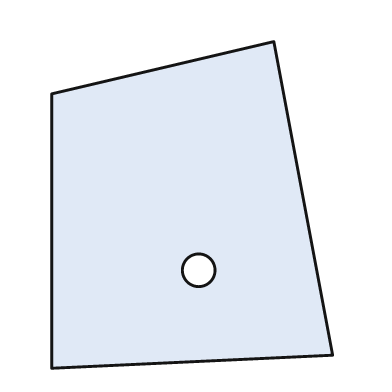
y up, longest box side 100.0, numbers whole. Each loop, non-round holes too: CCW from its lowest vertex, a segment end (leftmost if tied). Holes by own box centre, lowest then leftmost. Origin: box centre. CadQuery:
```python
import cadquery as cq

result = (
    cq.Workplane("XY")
    .moveTo(-43.0, -50.0)
    .lineTo(43.0, -46.0)
    .lineTo(25.0, 50.0)
    .lineTo(-43.0, 34.0)
    .close()
    .moveTo(2.0, -20.0)
    .circle(5.0)
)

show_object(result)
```